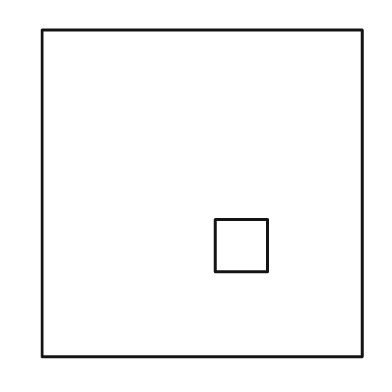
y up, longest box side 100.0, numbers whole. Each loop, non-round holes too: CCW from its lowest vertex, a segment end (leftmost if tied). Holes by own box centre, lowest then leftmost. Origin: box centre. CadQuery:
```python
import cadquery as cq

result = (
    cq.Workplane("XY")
    .moveTo(-49.0, -50.0)
    .lineTo(49.0, -50.0)
    .lineTo(49.0, 50.0)
    .lineTo(-49.0, 50.0)
    .close()
    .moveTo(4.0, -24.0)
    .lineTo(20.0, -24.0)
    .lineTo(20.0, -8.0)
    .lineTo(4.0, -8.0)
    .close()
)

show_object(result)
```